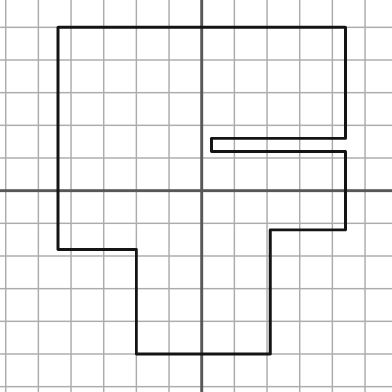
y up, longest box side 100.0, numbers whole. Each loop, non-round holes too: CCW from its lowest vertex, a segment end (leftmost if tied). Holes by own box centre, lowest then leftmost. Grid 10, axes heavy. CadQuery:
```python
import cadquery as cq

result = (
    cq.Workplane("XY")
    .moveTo(-20.0, -50.0)
    .lineTo(21.0, -50.0)
    .lineTo(21.0, -12.0)
    .lineTo(44.0, -12.0)
    .lineTo(44.0, 12.0)
    .lineTo(3.0, 12.0)
    .lineTo(3.0, 16.0)
    .lineTo(44.0, 16.0)
    .lineTo(44.0, 50.0)
    .lineTo(-44.0, 50.0)
    .lineTo(-44.0, -18.0)
    .lineTo(-20.0, -18.0)
    .close()
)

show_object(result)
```